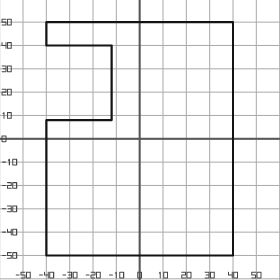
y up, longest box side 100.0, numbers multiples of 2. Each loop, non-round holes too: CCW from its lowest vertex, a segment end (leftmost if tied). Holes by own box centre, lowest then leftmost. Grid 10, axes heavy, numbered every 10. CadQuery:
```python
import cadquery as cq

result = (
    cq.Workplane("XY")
    .moveTo(-40.0, -50.0)
    .lineTo(40.0, -50.0)
    .lineTo(40.0, 50.0)
    .lineTo(-40.0, 50.0)
    .lineTo(-40.0, 40.0)
    .lineTo(-12.0, 40.0)
    .lineTo(-12.0, 8.0)
    .lineTo(-40.0, 8.0)
    .close()
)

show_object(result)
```